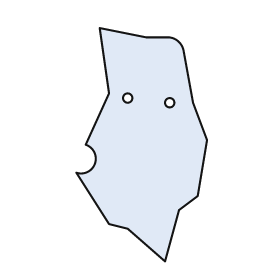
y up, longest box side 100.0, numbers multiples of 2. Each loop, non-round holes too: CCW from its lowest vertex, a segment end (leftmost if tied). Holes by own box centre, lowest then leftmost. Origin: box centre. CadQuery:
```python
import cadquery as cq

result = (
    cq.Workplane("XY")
    .moveTo(10.0, -50.0)
    .lineTo(16.0, -28.0)
    .lineTo(24.0, -22.0)
    .lineTo(28.0, 2.0)
    .lineTo(22.0, 18.0)
    .lineTo(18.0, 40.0)
    .threePointArc((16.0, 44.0), (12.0, 46.0))
    .lineTo(2.0, 46.0)
    .lineTo(-18.0, 50.0)
    .lineTo(-14.0, 22.0)
    .lineTo(-24.0, 0.0)
    .threePointArc((-20.0, -8.0), (-28.0, -12.0))
    .lineTo(-14.0, -34.0)
    .lineTo(-6.0, -36.0)
    .close()
    .moveTo(12.0, 18.0)
    .circle(2.0)
    .moveTo(-6.0, 20.0)
    .circle(2.0)
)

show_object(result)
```